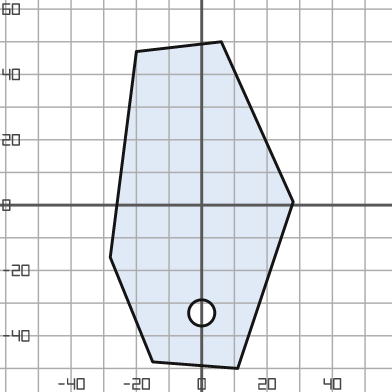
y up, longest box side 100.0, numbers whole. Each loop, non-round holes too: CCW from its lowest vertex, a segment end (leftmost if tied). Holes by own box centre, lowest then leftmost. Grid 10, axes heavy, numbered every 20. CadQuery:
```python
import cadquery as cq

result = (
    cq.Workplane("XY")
    .moveTo(11.0, -50.0)
    .lineTo(28.0, 1.0)
    .lineTo(6.0, 50.0)
    .lineTo(-20.0, 47.0)
    .lineTo(-28.0, -16.0)
    .lineTo(-15.0, -48.0)
    .close()
    .moveTo(0.0, -33.0)
    .circle(4.0)
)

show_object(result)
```